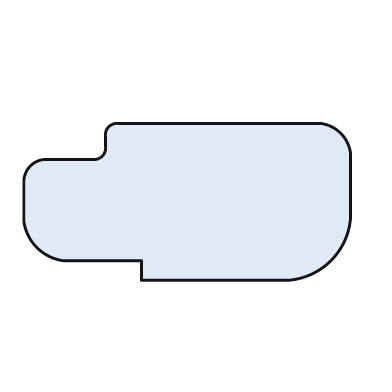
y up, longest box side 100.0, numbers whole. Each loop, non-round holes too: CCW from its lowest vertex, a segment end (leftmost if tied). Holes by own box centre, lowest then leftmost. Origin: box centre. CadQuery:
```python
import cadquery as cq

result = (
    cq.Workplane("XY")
    .moveTo(-14.0, -24.0)
    .lineTo(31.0, -24.0)
    .threePointArc((44.0, -18.0), (50.0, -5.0))
    .lineTo(50.0, 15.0)
    .threePointArc((47.0, 21.0), (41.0, 24.0))
    .lineTo(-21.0, 24.0)
    .threePointArc((-24.0, 23.0), (-25.0, 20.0))
    .lineTo(-25.0, 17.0)
    .threePointArc((-26.0, 14.0), (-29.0, 13.0))
    .lineTo(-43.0, 13.0)
    .threePointArc((-48.0, 11.0), (-50.0, 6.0))
    .lineTo(-50.0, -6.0)
    .threePointArc((-46.0, -14.0), (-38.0, -18.0))
    .lineTo(-14.0, -18.0)
    .close()
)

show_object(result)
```